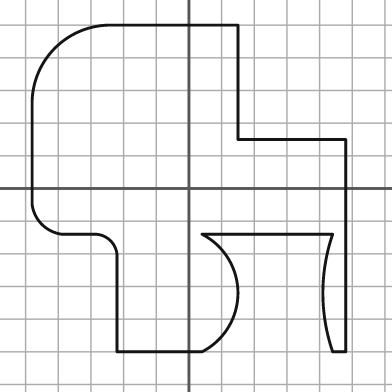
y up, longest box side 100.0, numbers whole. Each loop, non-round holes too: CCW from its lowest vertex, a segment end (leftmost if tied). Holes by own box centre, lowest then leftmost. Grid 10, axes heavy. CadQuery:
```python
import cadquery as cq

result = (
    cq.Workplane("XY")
    .moveTo(-22.0, -50.0)
    .lineTo(4.0, -50.0)
    .threePointArc((15.0, -32.0), (4.0, -14.0))
    .lineTo(44.0, -14.0)
    .threePointArc((41.0, -32.0), (44.0, -50.0))
    .lineTo(48.0, -50.0)
    .lineTo(48.0, 15.0)
    .lineTo(15.0, 15.0)
    .lineTo(15.0, 50.0)
    .lineTo(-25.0, 50.0)
    .threePointArc((-41.0, 43.0), (-48.0, 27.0))
    .lineTo(-48.0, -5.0)
    .threePointArc((-45.0, -11.0), (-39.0, -14.0))
    .lineTo(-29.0, -14.0)
    .threePointArc((-24.0, -16.0), (-22.0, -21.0))
    .close()
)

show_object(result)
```